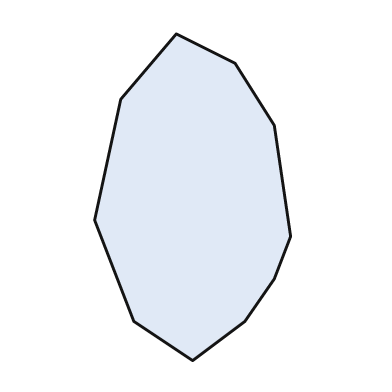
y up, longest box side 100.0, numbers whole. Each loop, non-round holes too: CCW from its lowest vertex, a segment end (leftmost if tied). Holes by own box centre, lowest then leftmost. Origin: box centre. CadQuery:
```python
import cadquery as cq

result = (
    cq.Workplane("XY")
    .moveTo(0.0, -50.0)
    .lineTo(16.0, -38.0)
    .lineTo(25.0, -25.0)
    .lineTo(30.0, -12.0)
    .lineTo(25.0, 22.0)
    .lineTo(13.0, 41.0)
    .lineTo(-5.0, 50.0)
    .lineTo(-22.0, 30.0)
    .lineTo(-30.0, -7.0)
    .lineTo(-18.0, -38.0)
    .close()
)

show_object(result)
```